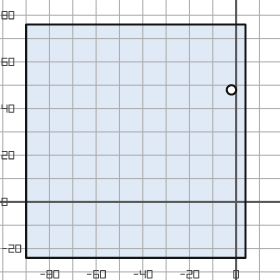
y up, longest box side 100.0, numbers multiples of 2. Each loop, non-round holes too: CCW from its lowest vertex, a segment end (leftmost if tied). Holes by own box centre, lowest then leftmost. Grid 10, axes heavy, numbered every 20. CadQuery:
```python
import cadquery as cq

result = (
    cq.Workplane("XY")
    .moveTo(-90.0, -24.0)
    .lineTo(4.0, -24.0)
    .lineTo(4.0, 76.0)
    .lineTo(-90.0, 76.0)
    .close()
    .moveTo(-2.0, 48.0)
    .circle(2.0)
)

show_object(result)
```